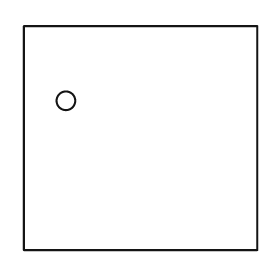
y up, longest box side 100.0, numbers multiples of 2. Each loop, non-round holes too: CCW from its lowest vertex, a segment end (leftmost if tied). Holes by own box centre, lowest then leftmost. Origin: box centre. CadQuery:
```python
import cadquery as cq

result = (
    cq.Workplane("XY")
    .moveTo(-50.0, -48.0)
    .lineTo(50.0, -48.0)
    .lineTo(50.0, 48.0)
    .lineTo(-50.0, 48.0)
    .close()
    .moveTo(-32.0, 16.0)
    .circle(4.0)
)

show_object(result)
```